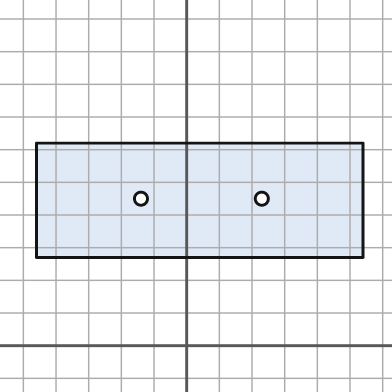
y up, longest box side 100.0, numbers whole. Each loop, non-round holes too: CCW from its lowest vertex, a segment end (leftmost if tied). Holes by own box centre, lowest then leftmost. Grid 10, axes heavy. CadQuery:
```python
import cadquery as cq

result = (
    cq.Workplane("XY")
    .moveTo(-46.0, 27.0)
    .lineTo(54.0, 27.0)
    .lineTo(54.0, 62.0)
    .lineTo(-46.0, 62.0)
    .close()
    .moveTo(-14.0, 45.0)
    .circle(2.0)
    .moveTo(23.0, 45.0)
    .circle(2.0)
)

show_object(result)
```